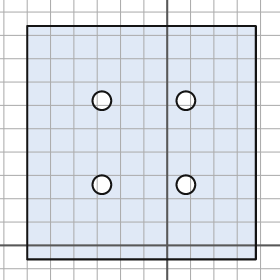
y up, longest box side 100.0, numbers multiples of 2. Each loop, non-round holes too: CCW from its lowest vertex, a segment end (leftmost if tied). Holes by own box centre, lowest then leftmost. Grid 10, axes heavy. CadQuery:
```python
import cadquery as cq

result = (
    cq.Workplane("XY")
    .moveTo(-60.0, -6.0)
    .lineTo(38.0, -6.0)
    .lineTo(38.0, 94.0)
    .lineTo(-60.0, 94.0)
    .close()
    .moveTo(-28.0, 26.0)
    .circle(4.0)
    .moveTo(8.0, 26.0)
    .circle(4.0)
    .moveTo(-28.0, 62.0)
    .circle(4.0)
    .moveTo(8.0, 62.0)
    .circle(4.0)
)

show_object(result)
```